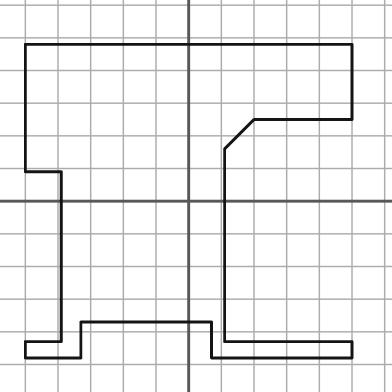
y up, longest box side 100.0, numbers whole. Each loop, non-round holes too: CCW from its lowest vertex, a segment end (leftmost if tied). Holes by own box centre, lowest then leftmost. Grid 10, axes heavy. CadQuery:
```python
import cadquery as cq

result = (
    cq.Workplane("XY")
    .moveTo(-50.0, -48.0)
    .lineTo(-33.0, -48.0)
    .lineTo(-33.0, -37.0)
    .lineTo(7.0, -37.0)
    .lineTo(7.0, -48.0)
    .lineTo(50.0, -48.0)
    .lineTo(50.0, -43.0)
    .lineTo(11.0, -43.0)
    .lineTo(11.0, 16.0)
    .lineTo(20.0, 25.0)
    .lineTo(50.0, 25.0)
    .lineTo(50.0, 48.0)
    .lineTo(-50.0, 48.0)
    .lineTo(-50.0, 9.0)
    .lineTo(-39.0, 9.0)
    .lineTo(-39.0, -43.0)
    .lineTo(-50.0, -43.0)
    .close()
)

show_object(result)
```